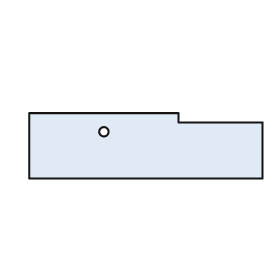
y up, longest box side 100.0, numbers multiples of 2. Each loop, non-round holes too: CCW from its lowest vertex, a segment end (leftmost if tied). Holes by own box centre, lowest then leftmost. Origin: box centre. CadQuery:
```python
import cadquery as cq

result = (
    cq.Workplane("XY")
    .moveTo(-50.0, -14.0)
    .lineTo(50.0, -14.0)
    .lineTo(50.0, 10.0)
    .lineTo(14.0, 10.0)
    .lineTo(14.0, 14.0)
    .lineTo(-50.0, 14.0)
    .close()
    .moveTo(-18.0, 6.0)
    .circle(2.0)
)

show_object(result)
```